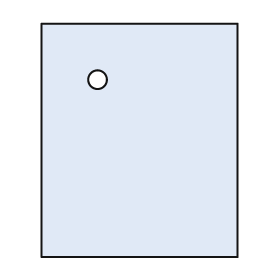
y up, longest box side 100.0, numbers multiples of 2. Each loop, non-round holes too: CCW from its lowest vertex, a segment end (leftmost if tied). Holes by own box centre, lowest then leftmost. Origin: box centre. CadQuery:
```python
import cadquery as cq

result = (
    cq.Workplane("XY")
    .moveTo(-42.0, -50.0)
    .lineTo(42.0, -50.0)
    .lineTo(42.0, 50.0)
    .lineTo(-42.0, 50.0)
    .close()
    .moveTo(-18.0, 26.0)
    .circle(4.0)
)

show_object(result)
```